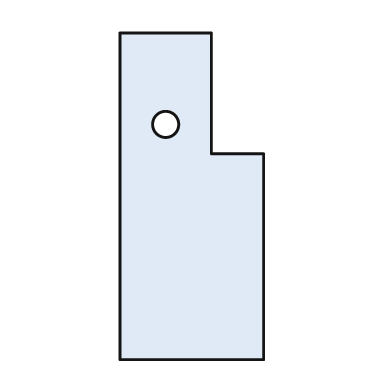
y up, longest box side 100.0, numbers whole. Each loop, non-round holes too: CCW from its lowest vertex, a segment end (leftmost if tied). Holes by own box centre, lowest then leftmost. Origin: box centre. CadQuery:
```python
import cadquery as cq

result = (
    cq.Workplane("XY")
    .moveTo(-22.0, -50.0)
    .lineTo(22.0, -50.0)
    .lineTo(22.0, 13.0)
    .lineTo(6.0, 13.0)
    .lineTo(6.0, 50.0)
    .lineTo(-22.0, 50.0)
    .close()
    .moveTo(-8.0, 22.0)
    .circle(4.0)
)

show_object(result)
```